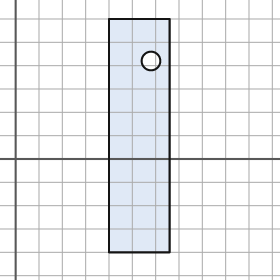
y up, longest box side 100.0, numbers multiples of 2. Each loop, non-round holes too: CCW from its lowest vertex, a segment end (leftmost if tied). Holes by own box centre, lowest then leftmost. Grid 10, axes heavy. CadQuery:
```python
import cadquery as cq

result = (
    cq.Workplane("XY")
    .moveTo(40.0, -40.0)
    .lineTo(66.0, -40.0)
    .lineTo(66.0, 60.0)
    .lineTo(40.0, 60.0)
    .close()
    .moveTo(58.0, 42.0)
    .circle(4.0)
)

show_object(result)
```